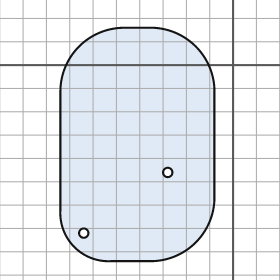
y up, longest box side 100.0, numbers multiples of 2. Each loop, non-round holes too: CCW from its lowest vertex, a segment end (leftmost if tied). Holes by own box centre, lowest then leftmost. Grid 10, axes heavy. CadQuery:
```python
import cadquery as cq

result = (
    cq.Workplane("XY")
    .moveTo(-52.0, -84.0)
    .lineTo(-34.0, -84.0)
    .threePointArc((-16.0, -76.0), (-8.0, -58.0))
    .lineTo(-8.0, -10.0)
    .threePointArc((-16.0, 8.0), (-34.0, 16.0))
    .lineTo(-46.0, 16.0)
    .threePointArc((-66.0, 8.0), (-74.0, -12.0))
    .lineTo(-74.0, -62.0)
    .threePointArc((-68.0, -78.0), (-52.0, -84.0))
    .close()
    .moveTo(-64.0, -72.0)
    .circle(2.0)
    .moveTo(-28.0, -46.0)
    .circle(2.0)
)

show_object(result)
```